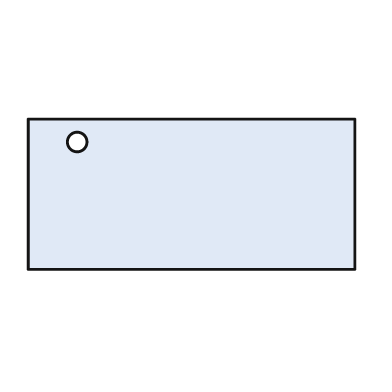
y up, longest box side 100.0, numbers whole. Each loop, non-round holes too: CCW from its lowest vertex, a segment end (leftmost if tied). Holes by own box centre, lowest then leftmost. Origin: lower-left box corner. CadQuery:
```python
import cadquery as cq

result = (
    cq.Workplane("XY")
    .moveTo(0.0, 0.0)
    .lineTo(100.0, 0.0)
    .lineTo(100.0, 46.0)
    .lineTo(0.0, 46.0)
    .close()
    .moveTo(15.0, 39.0)
    .circle(3.0)
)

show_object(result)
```